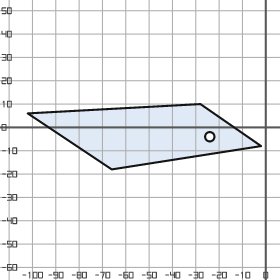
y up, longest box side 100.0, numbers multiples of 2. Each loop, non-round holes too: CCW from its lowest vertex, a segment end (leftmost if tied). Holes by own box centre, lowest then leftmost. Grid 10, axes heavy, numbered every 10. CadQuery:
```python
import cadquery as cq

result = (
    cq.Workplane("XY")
    .moveTo(-66.0, -18.0)
    .lineTo(-2.0, -8.0)
    .lineTo(-28.0, 10.0)
    .lineTo(-102.0, 6.0)
    .close()
    .moveTo(-24.0, -4.0)
    .circle(2.0)
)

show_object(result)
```